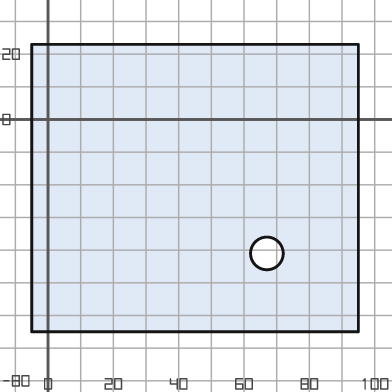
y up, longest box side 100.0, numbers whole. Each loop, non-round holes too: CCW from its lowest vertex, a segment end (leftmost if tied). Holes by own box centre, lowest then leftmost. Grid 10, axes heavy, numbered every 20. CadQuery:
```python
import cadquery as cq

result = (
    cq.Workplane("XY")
    .moveTo(-5.0, -65.0)
    .lineTo(95.0, -65.0)
    .lineTo(95.0, 23.0)
    .lineTo(-5.0, 23.0)
    .close()
    .moveTo(67.0, -41.0)
    .circle(5.0)
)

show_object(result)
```